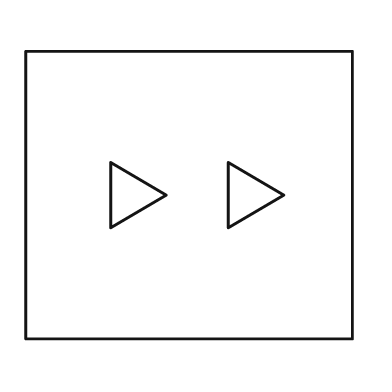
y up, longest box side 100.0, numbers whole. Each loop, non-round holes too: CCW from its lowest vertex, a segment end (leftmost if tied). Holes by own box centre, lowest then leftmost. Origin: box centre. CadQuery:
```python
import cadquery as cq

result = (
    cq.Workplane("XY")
    .moveTo(-50.0, -44.0)
    .lineTo(50.0, -44.0)
    .lineTo(50.0, 44.0)
    .lineTo(-50.0, 44.0)
    .close()
    .moveTo(-24.0, -10.0)
    .lineTo(-7.0, 0.0)
    .lineTo(-24.0, 10.0)
    .close()
    .moveTo(12.0, -10.0)
    .lineTo(29.0, 0.0)
    .lineTo(12.0, 10.0)
    .close()
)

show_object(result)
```